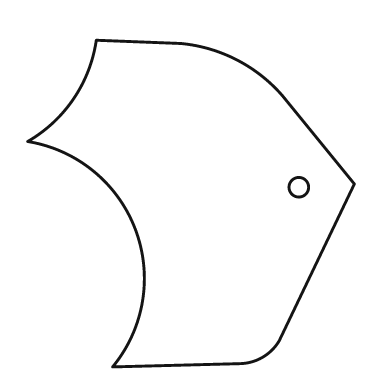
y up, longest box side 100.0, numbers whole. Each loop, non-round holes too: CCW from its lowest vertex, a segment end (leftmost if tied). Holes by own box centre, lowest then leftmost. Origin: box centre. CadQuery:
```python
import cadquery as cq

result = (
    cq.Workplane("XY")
    .moveTo(-24.0, -50.0)
    .lineTo(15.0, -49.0)
    .threePointArc((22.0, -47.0), (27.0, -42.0))
    .lineTo(50.0, 6.0)
    .lineTo(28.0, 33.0)
    .threePointArc((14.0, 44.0), (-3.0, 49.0))
    .lineTo(-29.0, 50.0)
    .threePointArc((-36.0, 32.0), (-50.0, 19.0))
    .threePointArc((-17.0, -8.0), (-24.0, -50.0))
    .close()
    .moveTo(33.0, 5.0)
    .circle(3.0)
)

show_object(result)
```